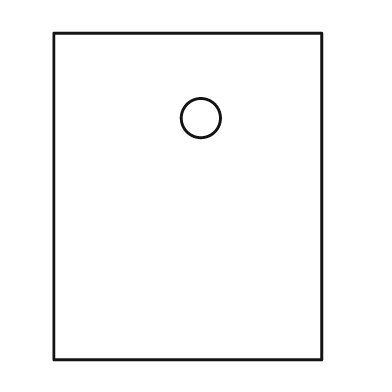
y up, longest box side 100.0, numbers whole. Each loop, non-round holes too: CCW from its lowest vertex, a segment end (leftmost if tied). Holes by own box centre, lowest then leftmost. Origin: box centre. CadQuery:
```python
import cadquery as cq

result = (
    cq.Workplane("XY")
    .moveTo(-41.0, -50.0)
    .lineTo(41.0, -50.0)
    .lineTo(41.0, 50.0)
    .lineTo(-41.0, 50.0)
    .close()
    .moveTo(4.0, 24.0)
    .circle(6.0)
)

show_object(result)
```